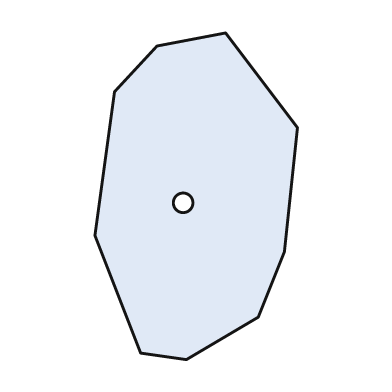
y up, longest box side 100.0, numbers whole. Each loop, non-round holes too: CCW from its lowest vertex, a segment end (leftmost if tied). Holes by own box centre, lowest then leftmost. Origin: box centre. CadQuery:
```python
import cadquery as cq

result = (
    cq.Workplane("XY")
    .moveTo(-3.0, -50.0)
    .lineTo(19.0, -37.0)
    .lineTo(27.0, -17.0)
    .lineTo(31.0, 21.0)
    .lineTo(9.0, 50.0)
    .lineTo(-12.0, 46.0)
    .lineTo(-25.0, 32.0)
    .lineTo(-31.0, -12.0)
    .lineTo(-17.0, -48.0)
    .close()
    .moveTo(-4.0, -2.0)
    .circle(3.0)
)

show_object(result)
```